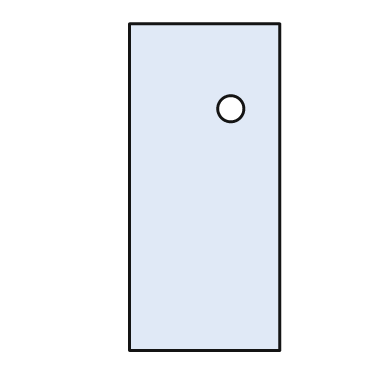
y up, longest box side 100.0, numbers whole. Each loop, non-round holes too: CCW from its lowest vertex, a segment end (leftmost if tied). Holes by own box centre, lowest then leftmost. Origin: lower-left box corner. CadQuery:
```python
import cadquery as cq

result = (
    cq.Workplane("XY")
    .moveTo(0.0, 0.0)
    .lineTo(46.0, 0.0)
    .lineTo(46.0, 100.0)
    .lineTo(0.0, 100.0)
    .close()
    .moveTo(31.0, 74.0)
    .circle(4.0)
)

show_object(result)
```